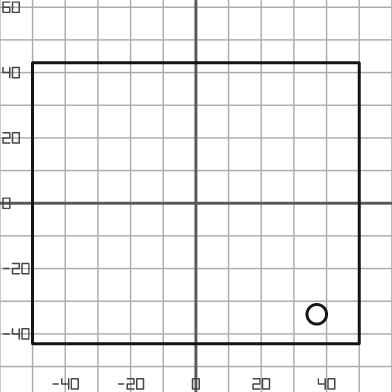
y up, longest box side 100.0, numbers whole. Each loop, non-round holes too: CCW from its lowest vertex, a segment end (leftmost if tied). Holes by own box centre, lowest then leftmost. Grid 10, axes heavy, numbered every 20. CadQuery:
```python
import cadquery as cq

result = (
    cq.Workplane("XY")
    .moveTo(-50.0, -43.0)
    .lineTo(50.0, -43.0)
    .lineTo(50.0, 43.0)
    .lineTo(-50.0, 43.0)
    .close()
    .moveTo(37.0, -34.0)
    .circle(3.0)
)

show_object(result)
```